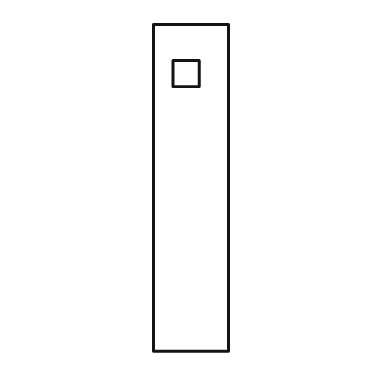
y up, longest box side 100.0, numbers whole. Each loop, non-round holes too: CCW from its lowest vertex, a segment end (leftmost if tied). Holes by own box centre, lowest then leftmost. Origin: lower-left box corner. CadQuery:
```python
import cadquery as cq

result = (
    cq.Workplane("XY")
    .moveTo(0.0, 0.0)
    .lineTo(23.0, 0.0)
    .lineTo(23.0, 100.0)
    .lineTo(0.0, 100.0)
    .close()
    .moveTo(6.0, 81.0)
    .lineTo(14.0, 81.0)
    .lineTo(14.0, 89.0)
    .lineTo(6.0, 89.0)
    .close()
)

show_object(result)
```